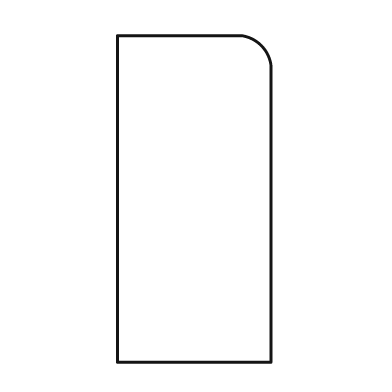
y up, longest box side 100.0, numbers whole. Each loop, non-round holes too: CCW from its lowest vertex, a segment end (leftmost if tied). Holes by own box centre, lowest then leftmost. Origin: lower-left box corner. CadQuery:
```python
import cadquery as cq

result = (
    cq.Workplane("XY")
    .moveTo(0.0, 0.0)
    .lineTo(47.0, 0.0)
    .lineTo(47.0, 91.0)
    .threePointArc((44.0, 97.0), (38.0, 100.0))
    .lineTo(0.0, 100.0)
    .close()
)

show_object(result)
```